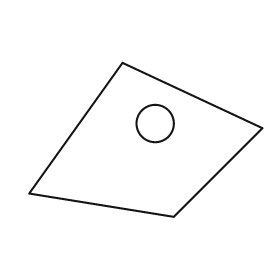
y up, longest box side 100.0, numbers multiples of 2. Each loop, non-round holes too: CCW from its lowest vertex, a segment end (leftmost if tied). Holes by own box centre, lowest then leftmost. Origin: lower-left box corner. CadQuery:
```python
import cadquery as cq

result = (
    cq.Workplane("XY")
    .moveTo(62.0, 0.0)
    .lineTo(100.0, 38.0)
    .lineTo(40.0, 66.0)
    .lineTo(0.0, 10.0)
    .close()
    .moveTo(54.0, 40.0)
    .circle(8.0)
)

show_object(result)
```